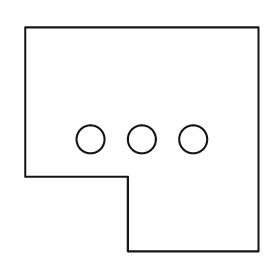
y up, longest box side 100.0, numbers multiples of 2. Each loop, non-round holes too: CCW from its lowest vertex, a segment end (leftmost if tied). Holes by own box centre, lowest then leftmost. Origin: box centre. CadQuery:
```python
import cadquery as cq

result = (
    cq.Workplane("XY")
    .moveTo(-6.0, -48.0)
    .lineTo(50.0, -48.0)
    .lineTo(50.0, 48.0)
    .lineTo(-50.0, 48.0)
    .lineTo(-50.0, -16.0)
    .lineTo(-6.0, -16.0)
    .close()
    .moveTo(-22.0, 0.0)
    .circle(6.0)
    .moveTo(0.0, 0.0)
    .circle(6.0)
    .moveTo(22.0, 0.0)
    .circle(6.0)
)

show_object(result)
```